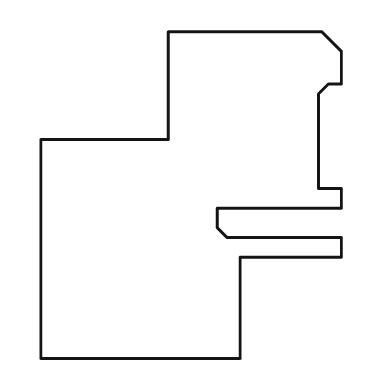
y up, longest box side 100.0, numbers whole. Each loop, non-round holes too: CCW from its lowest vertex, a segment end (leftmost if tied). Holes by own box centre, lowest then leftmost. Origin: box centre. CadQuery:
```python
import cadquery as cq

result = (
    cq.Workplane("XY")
    .moveTo(-46.0, -50.0)
    .lineTo(15.0, -50.0)
    .lineTo(15.0, -19.0)
    .lineTo(46.0, -19.0)
    .lineTo(46.0, -13.0)
    .lineTo(11.0, -13.0)
    .lineTo(8.0, -10.0)
    .lineTo(8.0, -4.0)
    .lineTo(46.0, -4.0)
    .lineTo(46.0, 2.0)
    .lineTo(39.0, 2.0)
    .lineTo(39.0, 31.0)
    .lineTo(42.0, 34.0)
    .lineTo(46.0, 34.0)
    .lineTo(46.0, 44.0)
    .lineTo(40.0, 50.0)
    .lineTo(-7.0, 50.0)
    .lineTo(-7.0, 17.0)
    .lineTo(-46.0, 17.0)
    .close()
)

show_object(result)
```